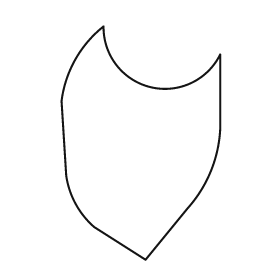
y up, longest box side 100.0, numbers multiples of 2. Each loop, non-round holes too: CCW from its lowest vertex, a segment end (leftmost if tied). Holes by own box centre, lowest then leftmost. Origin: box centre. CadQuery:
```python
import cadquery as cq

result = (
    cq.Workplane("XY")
    .moveTo(2.0, -50.0)
    .lineTo(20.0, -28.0)
    .threePointArc((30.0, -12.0), (34.0, 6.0))
    .lineTo(34.0, 38.0)
    .threePointArc((4.0, 24.0), (-16.0, 50.0))
    .threePointArc((-28.0, 36.0), (-34.0, 18.0))
    .lineTo(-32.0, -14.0)
    .threePointArc((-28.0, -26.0), (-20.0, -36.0))
    .close()
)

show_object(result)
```